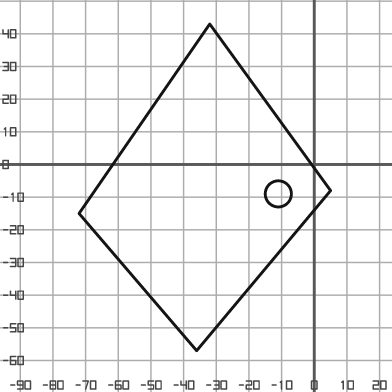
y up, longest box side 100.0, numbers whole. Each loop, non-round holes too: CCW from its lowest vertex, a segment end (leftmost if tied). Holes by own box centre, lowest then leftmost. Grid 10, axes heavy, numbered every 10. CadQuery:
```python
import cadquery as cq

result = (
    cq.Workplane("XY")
    .moveTo(-36.0, -57.0)
    .lineTo(5.0, -8.0)
    .lineTo(-32.0, 43.0)
    .lineTo(-72.0, -15.0)
    .close()
    .moveTo(-11.0, -9.0)
    .circle(4.0)
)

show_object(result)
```